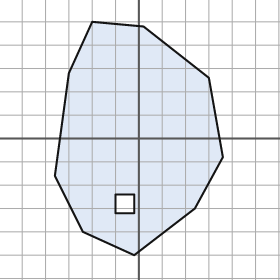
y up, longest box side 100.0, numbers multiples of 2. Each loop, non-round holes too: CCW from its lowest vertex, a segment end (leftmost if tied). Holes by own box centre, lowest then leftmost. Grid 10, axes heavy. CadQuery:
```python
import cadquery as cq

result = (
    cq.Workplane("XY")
    .moveTo(-2.0, -50.0)
    .lineTo(24.0, -30.0)
    .lineTo(36.0, -8.0)
    .lineTo(30.0, 26.0)
    .lineTo(2.0, 48.0)
    .lineTo(-20.0, 50.0)
    .lineTo(-30.0, 28.0)
    .lineTo(-36.0, -16.0)
    .lineTo(-24.0, -40.0)
    .close()
    .moveTo(-10.0, -32.0)
    .lineTo(-2.0, -32.0)
    .lineTo(-2.0, -24.0)
    .lineTo(-10.0, -24.0)
    .close()
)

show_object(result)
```